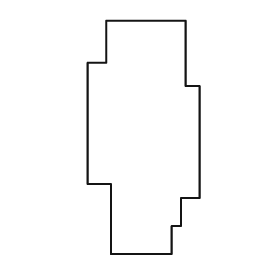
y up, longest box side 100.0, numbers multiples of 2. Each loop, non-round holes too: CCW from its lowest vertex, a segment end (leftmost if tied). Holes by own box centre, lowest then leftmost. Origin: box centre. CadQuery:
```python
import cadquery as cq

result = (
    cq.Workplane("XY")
    .moveTo(-14.0, -50.0)
    .lineTo(12.0, -50.0)
    .lineTo(12.0, -38.0)
    .lineTo(16.0, -38.0)
    .lineTo(16.0, -26.0)
    .lineTo(24.0, -26.0)
    .lineTo(24.0, 22.0)
    .lineTo(18.0, 22.0)
    .lineTo(18.0, 50.0)
    .lineTo(-16.0, 50.0)
    .lineTo(-16.0, 32.0)
    .lineTo(-24.0, 32.0)
    .lineTo(-24.0, -20.0)
    .lineTo(-14.0, -20.0)
    .close()
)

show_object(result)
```